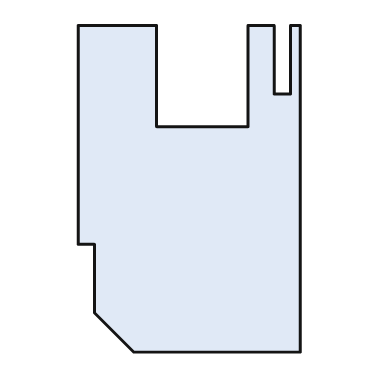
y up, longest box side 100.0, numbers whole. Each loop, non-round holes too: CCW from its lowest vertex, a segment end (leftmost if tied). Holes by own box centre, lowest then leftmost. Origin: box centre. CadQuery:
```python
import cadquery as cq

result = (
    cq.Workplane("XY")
    .moveTo(-17.0, -50.0)
    .lineTo(34.0, -50.0)
    .lineTo(34.0, 50.0)
    .lineTo(31.0, 50.0)
    .lineTo(31.0, 29.0)
    .lineTo(26.0, 29.0)
    .lineTo(26.0, 50.0)
    .lineTo(18.0, 50.0)
    .lineTo(18.0, 19.0)
    .lineTo(-10.0, 19.0)
    .lineTo(-10.0, 50.0)
    .lineTo(-34.0, 50.0)
    .lineTo(-34.0, -17.0)
    .lineTo(-29.0, -17.0)
    .lineTo(-29.0, -38.0)
    .close()
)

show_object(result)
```